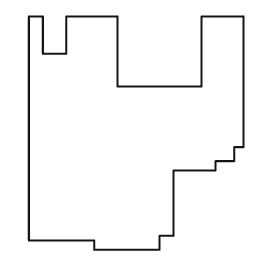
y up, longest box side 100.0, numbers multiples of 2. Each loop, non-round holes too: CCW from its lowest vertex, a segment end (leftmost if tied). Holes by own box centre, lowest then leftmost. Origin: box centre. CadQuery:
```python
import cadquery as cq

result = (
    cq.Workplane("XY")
    .moveTo(-18.0, -50.0)
    .lineTo(10.0, -50.0)
    .lineTo(10.0, -44.0)
    .lineTo(16.0, -44.0)
    .lineTo(16.0, -16.0)
    .lineTo(34.0, -16.0)
    .lineTo(34.0, -12.0)
    .lineTo(42.0, -12.0)
    .lineTo(42.0, -6.0)
    .lineTo(46.0, -6.0)
    .lineTo(46.0, 50.0)
    .lineTo(28.0, 50.0)
    .lineTo(28.0, 20.0)
    .lineTo(-8.0, 20.0)
    .lineTo(-8.0, 50.0)
    .lineTo(-30.0, 50.0)
    .lineTo(-30.0, 34.0)
    .lineTo(-40.0, 34.0)
    .lineTo(-40.0, 50.0)
    .lineTo(-46.0, 50.0)
    .lineTo(-46.0, -46.0)
    .lineTo(-18.0, -46.0)
    .close()
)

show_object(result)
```